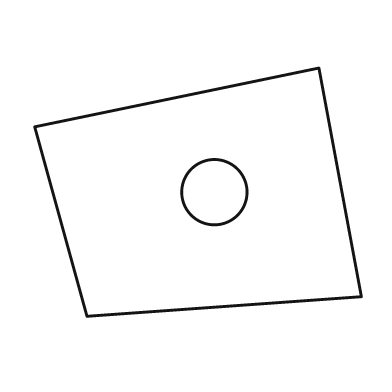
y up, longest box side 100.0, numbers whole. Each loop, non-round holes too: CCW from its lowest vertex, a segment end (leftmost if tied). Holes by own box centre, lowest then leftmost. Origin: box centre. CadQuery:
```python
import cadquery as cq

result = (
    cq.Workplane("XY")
    .moveTo(-34.0, -38.0)
    .lineTo(50.0, -32.0)
    .lineTo(37.0, 38.0)
    .lineTo(-50.0, 20.0)
    .close()
    .moveTo(5.0, 0.0)
    .circle(10.0)
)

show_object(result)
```